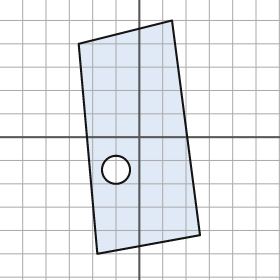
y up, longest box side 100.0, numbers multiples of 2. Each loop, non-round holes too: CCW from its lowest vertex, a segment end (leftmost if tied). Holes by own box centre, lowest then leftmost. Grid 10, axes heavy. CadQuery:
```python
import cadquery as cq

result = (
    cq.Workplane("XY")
    .moveTo(-18.0, -50.0)
    .lineTo(26.0, -42.0)
    .lineTo(14.0, 50.0)
    .lineTo(-26.0, 40.0)
    .close()
    .moveTo(-10.0, -14.0)
    .circle(6.0)
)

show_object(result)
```